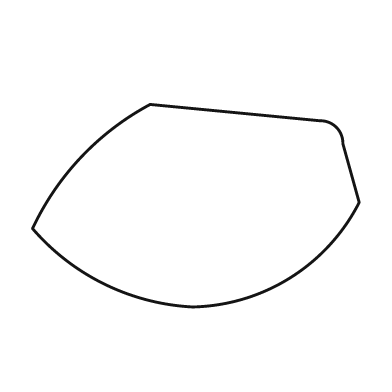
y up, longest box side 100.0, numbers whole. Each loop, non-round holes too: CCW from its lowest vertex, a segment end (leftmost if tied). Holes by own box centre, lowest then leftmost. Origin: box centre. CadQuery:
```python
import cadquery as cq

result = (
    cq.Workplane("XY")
    .moveTo(-1.0, -31.0)
    .threePointArc((29.0, -22.0), (50.0, 1.0))
    .lineTo(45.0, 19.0)
    .threePointArc((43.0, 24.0), (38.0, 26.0))
    .lineTo(-14.0, 31.0)
    .threePointArc((-35.0, 15.0), (-50.0, -7.0))
    .threePointArc((-28.0, -24.0), (-1.0, -31.0))
    .close()
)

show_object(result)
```